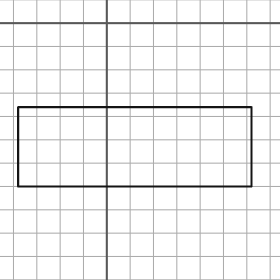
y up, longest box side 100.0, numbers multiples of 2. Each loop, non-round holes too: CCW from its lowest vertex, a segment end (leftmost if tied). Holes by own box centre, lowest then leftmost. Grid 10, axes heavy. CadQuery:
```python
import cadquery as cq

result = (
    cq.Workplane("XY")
    .moveTo(-38.0, -70.0)
    .lineTo(62.0, -70.0)
    .lineTo(62.0, -36.0)
    .lineTo(-38.0, -36.0)
    .close()
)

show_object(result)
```